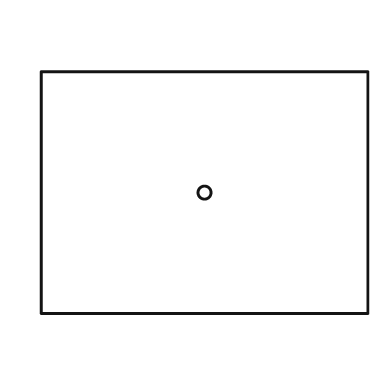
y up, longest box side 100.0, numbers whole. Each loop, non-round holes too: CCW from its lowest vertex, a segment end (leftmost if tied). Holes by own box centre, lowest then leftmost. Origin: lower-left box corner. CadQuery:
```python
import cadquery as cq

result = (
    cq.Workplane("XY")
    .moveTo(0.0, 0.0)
    .lineTo(100.0, 0.0)
    .lineTo(100.0, 74.0)
    .lineTo(0.0, 74.0)
    .close()
    .moveTo(50.0, 37.0)
    .circle(2.0)
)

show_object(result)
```